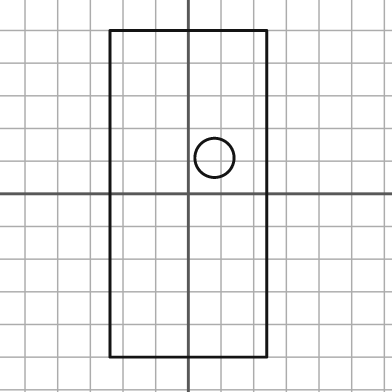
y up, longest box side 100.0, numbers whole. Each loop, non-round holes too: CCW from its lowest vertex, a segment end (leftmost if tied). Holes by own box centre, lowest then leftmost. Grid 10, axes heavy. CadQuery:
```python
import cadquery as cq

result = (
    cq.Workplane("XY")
    .moveTo(-24.0, -50.0)
    .lineTo(24.0, -50.0)
    .lineTo(24.0, 50.0)
    .lineTo(-24.0, 50.0)
    .close()
    .moveTo(8.0, 11.0)
    .circle(6.0)
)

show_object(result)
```